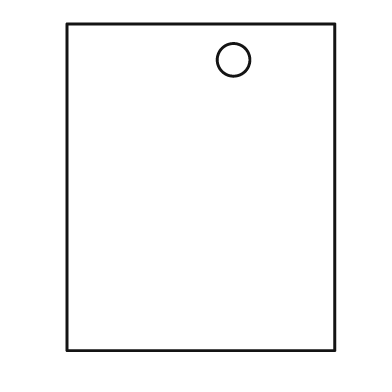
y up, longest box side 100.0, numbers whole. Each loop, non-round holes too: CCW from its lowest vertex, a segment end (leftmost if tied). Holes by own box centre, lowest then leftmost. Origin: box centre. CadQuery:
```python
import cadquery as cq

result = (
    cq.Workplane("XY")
    .moveTo(-41.0, -50.0)
    .lineTo(41.0, -50.0)
    .lineTo(41.0, 50.0)
    .lineTo(-41.0, 50.0)
    .close()
    .moveTo(10.0, 39.0)
    .circle(5.0)
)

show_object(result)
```